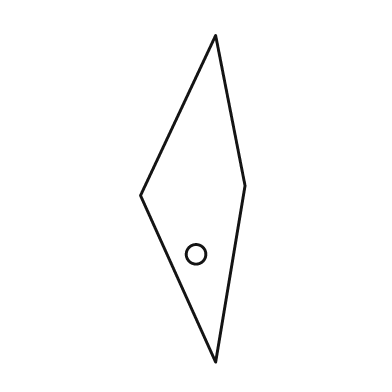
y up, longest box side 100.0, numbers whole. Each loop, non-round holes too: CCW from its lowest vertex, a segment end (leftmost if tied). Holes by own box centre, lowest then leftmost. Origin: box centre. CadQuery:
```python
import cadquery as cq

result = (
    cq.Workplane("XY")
    .moveTo(7.0, -50.0)
    .lineTo(16.0, 4.0)
    .lineTo(7.0, 50.0)
    .lineTo(-16.0, 1.0)
    .close()
    .moveTo(1.0, -17.0)
    .circle(3.0)
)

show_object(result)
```